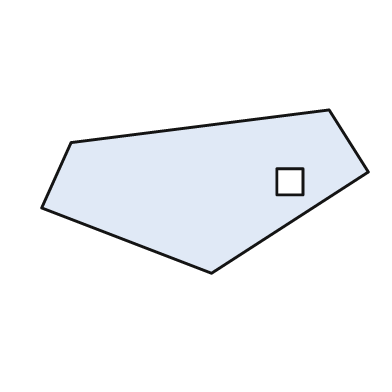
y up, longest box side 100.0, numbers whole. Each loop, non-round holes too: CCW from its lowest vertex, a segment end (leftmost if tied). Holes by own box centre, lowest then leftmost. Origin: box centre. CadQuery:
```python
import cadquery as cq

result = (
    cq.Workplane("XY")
    .moveTo(2.0, -25.0)
    .lineTo(50.0, 6.0)
    .lineTo(38.0, 25.0)
    .lineTo(-41.0, 15.0)
    .lineTo(-50.0, -5.0)
    .close()
    .moveTo(22.0, -1.0)
    .lineTo(30.0, -1.0)
    .lineTo(30.0, 7.0)
    .lineTo(22.0, 7.0)
    .close()
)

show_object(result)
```